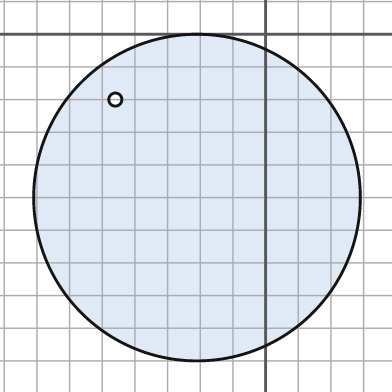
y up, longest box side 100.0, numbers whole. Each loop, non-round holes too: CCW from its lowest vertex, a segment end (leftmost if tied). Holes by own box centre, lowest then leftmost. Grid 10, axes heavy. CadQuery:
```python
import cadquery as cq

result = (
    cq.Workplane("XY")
    .moveTo(-21.0, -50.0)
    .circle(50.0)
    .moveTo(-46.0, -20.0)
    .circle(2.0)
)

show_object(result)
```